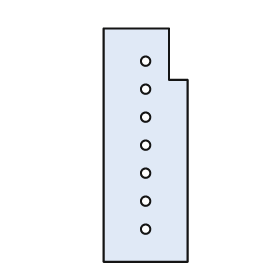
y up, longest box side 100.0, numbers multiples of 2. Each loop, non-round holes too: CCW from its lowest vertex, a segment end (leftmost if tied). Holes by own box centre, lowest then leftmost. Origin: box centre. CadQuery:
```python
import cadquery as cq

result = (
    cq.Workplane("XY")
    .moveTo(-18.0, -50.0)
    .lineTo(18.0, -50.0)
    .lineTo(18.0, 28.0)
    .lineTo(10.0, 28.0)
    .lineTo(10.0, 50.0)
    .lineTo(-18.0, 50.0)
    .close()
    .moveTo(0.0, -36.0)
    .circle(2.0)
    .moveTo(0.0, -24.0)
    .circle(2.0)
    .moveTo(0.0, -12.0)
    .circle(2.0)
    .moveTo(0.0, 0.0)
    .circle(2.0)
    .moveTo(0.0, 12.0)
    .circle(2.0)
    .moveTo(0.0, 24.0)
    .circle(2.0)
    .moveTo(0.0, 36.0)
    .circle(2.0)
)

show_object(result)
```